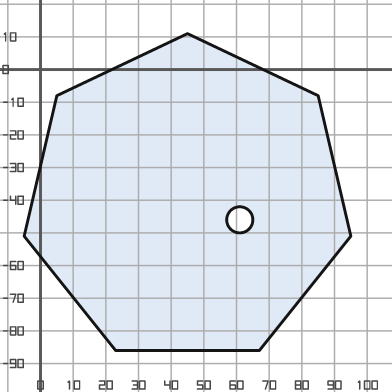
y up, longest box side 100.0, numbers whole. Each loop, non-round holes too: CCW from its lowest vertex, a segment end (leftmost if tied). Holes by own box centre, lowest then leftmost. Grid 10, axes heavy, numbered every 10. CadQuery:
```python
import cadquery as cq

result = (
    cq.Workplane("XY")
    .moveTo(23.0, -86.0)
    .lineTo(67.0, -86.0)
    .lineTo(95.0, -51.0)
    .lineTo(85.0, -8.0)
    .lineTo(45.0, 11.0)
    .lineTo(5.0, -8.0)
    .lineTo(-5.0, -51.0)
    .close()
    .moveTo(61.0, -46.0)
    .circle(4.0)
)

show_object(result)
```